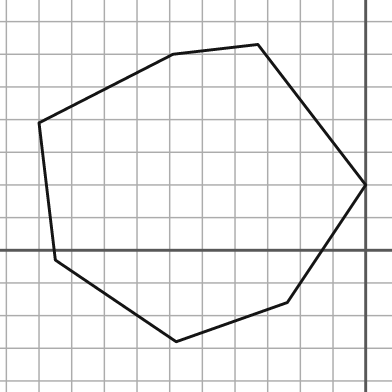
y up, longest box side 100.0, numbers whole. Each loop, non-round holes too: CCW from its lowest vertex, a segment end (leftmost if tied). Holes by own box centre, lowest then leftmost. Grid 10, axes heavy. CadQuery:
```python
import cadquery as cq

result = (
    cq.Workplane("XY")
    .moveTo(-58.0, -28.0)
    .lineTo(-24.0, -16.0)
    .lineTo(0.0, 20.0)
    .lineTo(-33.0, 63.0)
    .lineTo(-59.0, 60.0)
    .lineTo(-100.0, 39.0)
    .lineTo(-95.0, -3.0)
    .close()
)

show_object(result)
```